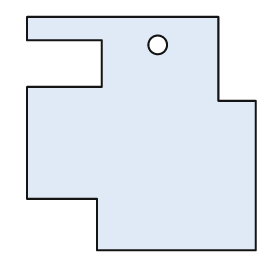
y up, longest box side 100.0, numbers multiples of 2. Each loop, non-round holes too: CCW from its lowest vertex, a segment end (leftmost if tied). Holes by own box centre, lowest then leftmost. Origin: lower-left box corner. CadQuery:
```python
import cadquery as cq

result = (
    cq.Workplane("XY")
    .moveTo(30.0, 0.0)
    .lineTo(98.0, 0.0)
    .lineTo(98.0, 64.0)
    .lineTo(82.0, 64.0)
    .lineTo(82.0, 100.0)
    .lineTo(0.0, 100.0)
    .lineTo(0.0, 90.0)
    .lineTo(32.0, 90.0)
    .lineTo(32.0, 70.0)
    .lineTo(0.0, 70.0)
    .lineTo(0.0, 22.0)
    .lineTo(30.0, 22.0)
    .close()
    .moveTo(56.0, 88.0)
    .circle(4.0)
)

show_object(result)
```